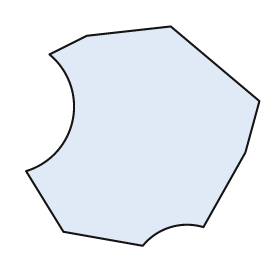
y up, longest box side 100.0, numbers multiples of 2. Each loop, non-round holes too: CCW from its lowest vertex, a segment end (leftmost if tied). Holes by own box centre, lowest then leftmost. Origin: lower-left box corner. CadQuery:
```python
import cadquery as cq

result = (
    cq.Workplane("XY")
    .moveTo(50.0, 0.0)
    .threePointArc((62.0, 8.0), (76.0, 8.0))
    .lineTo(94.0, 40.0)
    .lineTo(100.0, 62.0)
    .lineTo(62.0, 94.0)
    .lineTo(26.0, 90.0)
    .lineTo(10.0, 82.0)
    .threePointArc((20.0, 54.0), (0.0, 32.0))
    .lineTo(16.0, 6.0)
    .close()
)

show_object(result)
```